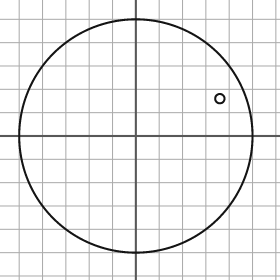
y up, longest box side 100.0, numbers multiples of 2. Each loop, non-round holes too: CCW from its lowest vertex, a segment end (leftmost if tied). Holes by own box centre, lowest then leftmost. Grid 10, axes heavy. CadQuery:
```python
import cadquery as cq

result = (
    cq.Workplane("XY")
    .moveTo(0.0, 0.0)
    .circle(50.0)
    .moveTo(36.0, 16.0)
    .circle(2.0)
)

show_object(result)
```